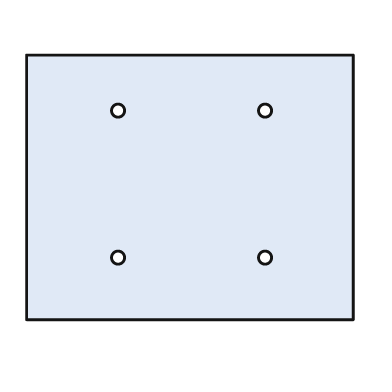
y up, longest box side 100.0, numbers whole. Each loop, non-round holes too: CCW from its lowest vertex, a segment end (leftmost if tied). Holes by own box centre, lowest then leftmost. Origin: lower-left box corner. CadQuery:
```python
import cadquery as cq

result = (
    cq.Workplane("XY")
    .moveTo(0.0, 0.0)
    .lineTo(100.0, 0.0)
    .lineTo(100.0, 81.0)
    .lineTo(0.0, 81.0)
    .close()
    .moveTo(28.0, 19.0)
    .circle(2.0)
    .moveTo(73.0, 19.0)
    .circle(2.0)
    .moveTo(28.0, 64.0)
    .circle(2.0)
    .moveTo(73.0, 64.0)
    .circle(2.0)
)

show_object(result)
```